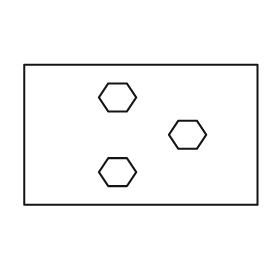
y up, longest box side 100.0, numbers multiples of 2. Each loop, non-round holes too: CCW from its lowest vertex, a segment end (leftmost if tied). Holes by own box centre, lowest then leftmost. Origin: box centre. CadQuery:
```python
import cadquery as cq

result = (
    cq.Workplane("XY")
    .moveTo(-50.0, -30.0)
    .lineTo(50.0, -30.0)
    .lineTo(50.0, 30.0)
    .lineTo(-50.0, 30.0)
    .close()
    .moveTo(-14.0, -22.0)
    .lineTo(-6.0, -22.0)
    .lineTo(-2.0, -16.0)
    .lineTo(-6.0, -10.0)
    .lineTo(-14.0, -10.0)
    .lineTo(-18.0, -16.0)
    .close()
    .moveTo(16.0, -6.0)
    .lineTo(24.0, -6.0)
    .lineTo(28.0, 0.0)
    .lineTo(24.0, 6.0)
    .lineTo(16.0, 6.0)
    .lineTo(12.0, 0.0)
    .close()
    .moveTo(-14.0, 10.0)
    .lineTo(-6.0, 10.0)
    .lineTo(-2.0, 16.0)
    .lineTo(-6.0, 22.0)
    .lineTo(-14.0, 22.0)
    .lineTo(-18.0, 16.0)
    .close()
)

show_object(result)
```